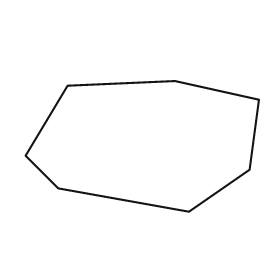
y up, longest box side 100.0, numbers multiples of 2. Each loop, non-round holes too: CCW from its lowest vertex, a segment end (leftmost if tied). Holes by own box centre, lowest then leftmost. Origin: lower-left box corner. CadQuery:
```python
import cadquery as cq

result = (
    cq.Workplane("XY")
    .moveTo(70.0, 0.0)
    .lineTo(96.0, 18.0)
    .lineTo(100.0, 48.0)
    .lineTo(64.0, 56.0)
    .lineTo(18.0, 54.0)
    .lineTo(0.0, 24.0)
    .lineTo(14.0, 10.0)
    .close()
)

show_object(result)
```